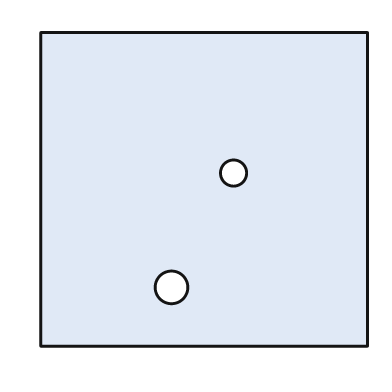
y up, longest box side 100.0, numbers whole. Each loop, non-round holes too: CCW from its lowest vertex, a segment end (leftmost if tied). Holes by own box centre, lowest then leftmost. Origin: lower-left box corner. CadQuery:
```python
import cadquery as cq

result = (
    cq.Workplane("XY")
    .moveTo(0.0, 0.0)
    .lineTo(100.0, 0.0)
    .lineTo(100.0, 96.0)
    .lineTo(0.0, 96.0)
    .close()
    .moveTo(40.0, 18.0)
    .circle(5.0)
    .moveTo(59.0, 53.0)
    .circle(4.0)
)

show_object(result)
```